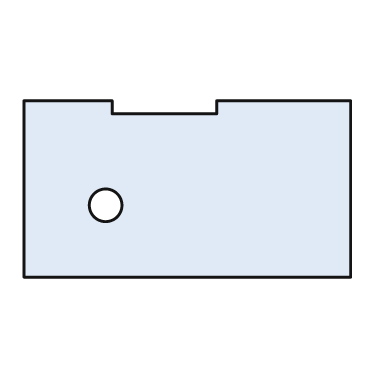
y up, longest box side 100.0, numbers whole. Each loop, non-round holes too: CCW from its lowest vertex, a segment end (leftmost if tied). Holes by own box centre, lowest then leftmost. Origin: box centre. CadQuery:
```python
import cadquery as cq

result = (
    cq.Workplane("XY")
    .moveTo(-50.0, -27.0)
    .lineTo(50.0, -27.0)
    .lineTo(50.0, 27.0)
    .lineTo(9.0, 27.0)
    .lineTo(9.0, 23.0)
    .lineTo(-23.0, 23.0)
    .lineTo(-23.0, 27.0)
    .lineTo(-50.0, 27.0)
    .close()
    .moveTo(-25.0, -5.0)
    .circle(5.0)
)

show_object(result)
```